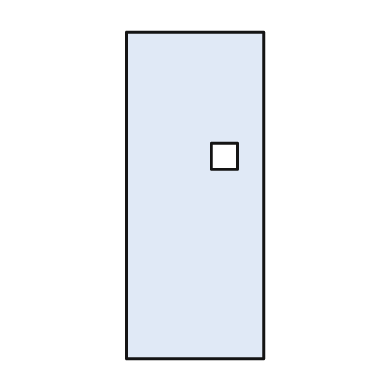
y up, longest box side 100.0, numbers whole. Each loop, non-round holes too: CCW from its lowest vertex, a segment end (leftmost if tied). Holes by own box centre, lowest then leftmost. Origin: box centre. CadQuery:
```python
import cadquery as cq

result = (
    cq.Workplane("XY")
    .moveTo(-21.0, -50.0)
    .lineTo(21.0, -50.0)
    .lineTo(21.0, 50.0)
    .lineTo(-21.0, 50.0)
    .close()
    .moveTo(5.0, 8.0)
    .lineTo(13.0, 8.0)
    .lineTo(13.0, 16.0)
    .lineTo(5.0, 16.0)
    .close()
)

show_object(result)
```